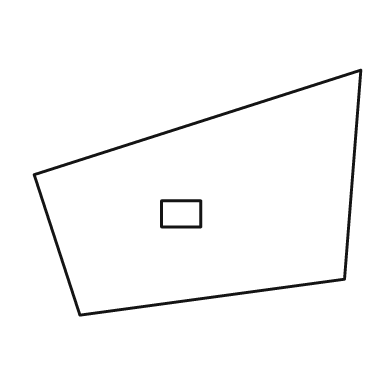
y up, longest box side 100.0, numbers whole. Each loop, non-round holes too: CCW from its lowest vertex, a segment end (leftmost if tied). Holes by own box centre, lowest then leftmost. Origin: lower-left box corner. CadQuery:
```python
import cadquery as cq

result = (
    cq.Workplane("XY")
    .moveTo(14.0, 0.0)
    .lineTo(95.0, 11.0)
    .lineTo(100.0, 75.0)
    .lineTo(0.0, 43.0)
    .close()
    .moveTo(39.0, 27.0)
    .lineTo(51.0, 27.0)
    .lineTo(51.0, 35.0)
    .lineTo(39.0, 35.0)
    .close()
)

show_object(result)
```